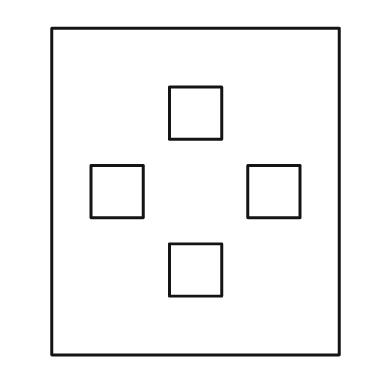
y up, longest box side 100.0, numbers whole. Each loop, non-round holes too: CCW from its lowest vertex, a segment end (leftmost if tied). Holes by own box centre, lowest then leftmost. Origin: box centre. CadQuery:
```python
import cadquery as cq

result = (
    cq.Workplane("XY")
    .moveTo(-44.0, -50.0)
    .lineTo(44.0, -50.0)
    .lineTo(44.0, 50.0)
    .lineTo(-44.0, 50.0)
    .close()
    .moveTo(-8.0, -32.0)
    .lineTo(8.0, -32.0)
    .lineTo(8.0, -16.0)
    .lineTo(-8.0, -16.0)
    .close()
    .moveTo(-32.0, -8.0)
    .lineTo(-16.0, -8.0)
    .lineTo(-16.0, 8.0)
    .lineTo(-32.0, 8.0)
    .close()
    .moveTo(16.0, -8.0)
    .lineTo(32.0, -8.0)
    .lineTo(32.0, 8.0)
    .lineTo(16.0, 8.0)
    .close()
    .moveTo(-8.0, 16.0)
    .lineTo(8.0, 16.0)
    .lineTo(8.0, 32.0)
    .lineTo(-8.0, 32.0)
    .close()
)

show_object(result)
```